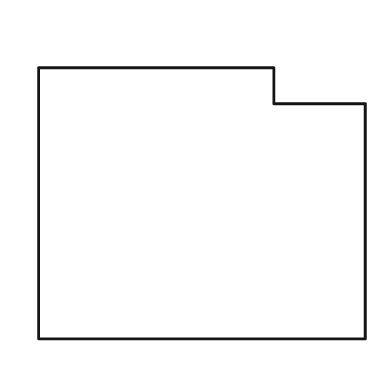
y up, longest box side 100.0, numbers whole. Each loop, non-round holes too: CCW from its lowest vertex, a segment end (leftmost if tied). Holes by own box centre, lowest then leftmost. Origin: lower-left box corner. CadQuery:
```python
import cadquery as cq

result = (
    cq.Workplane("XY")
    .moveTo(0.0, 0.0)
    .lineTo(100.0, 0.0)
    .lineTo(100.0, 72.0)
    .lineTo(72.0, 72.0)
    .lineTo(72.0, 83.0)
    .lineTo(0.0, 83.0)
    .close()
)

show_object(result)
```